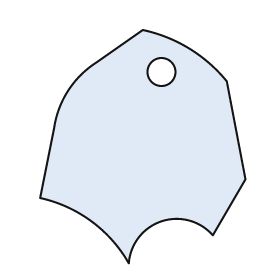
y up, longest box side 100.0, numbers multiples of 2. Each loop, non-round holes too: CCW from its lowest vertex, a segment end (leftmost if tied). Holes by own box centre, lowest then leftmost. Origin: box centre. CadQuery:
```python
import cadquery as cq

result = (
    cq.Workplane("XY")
    .moveTo(-6.0, -50.0)
    .threePointArc((8.0, -32.0), (30.0, -38.0))
    .lineTo(44.0, -14.0)
    .lineTo(36.0, 28.0)
    .threePointArc((20.0, 42.0), (0.0, 50.0))
    .lineTo(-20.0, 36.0)
    .threePointArc((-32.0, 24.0), (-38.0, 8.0))
    .lineTo(-44.0, -22.0)
    .threePointArc((-22.0, -32.0), (-6.0, -50.0))
    .close()
    .moveTo(8.0, 32.0)
    .circle(6.0)
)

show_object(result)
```